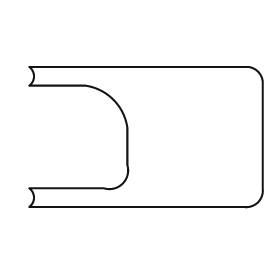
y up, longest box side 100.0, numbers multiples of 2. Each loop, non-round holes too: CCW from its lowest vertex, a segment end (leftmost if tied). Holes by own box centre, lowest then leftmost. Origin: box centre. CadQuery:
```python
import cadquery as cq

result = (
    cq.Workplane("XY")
    .moveTo(-50.0, -30.0)
    .lineTo(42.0, -30.0)
    .threePointArc((48.0, -28.0), (50.0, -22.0))
    .lineTo(50.0, 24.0)
    .threePointArc((48.0, 28.0), (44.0, 30.0))
    .lineTo(-50.0, 30.0)
    .threePointArc((-48.0, 26.0), (-50.0, 22.0))
    .lineTo(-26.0, 22.0)
    .threePointArc((-14.0, 16.0), (-8.0, 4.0))
    .lineTo(-8.0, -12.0)
    .threePointArc((-10.0, -20.0), (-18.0, -22.0))
    .lineTo(-50.0, -22.0)
    .threePointArc((-48.0, -26.0), (-50.0, -30.0))
    .close()
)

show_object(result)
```